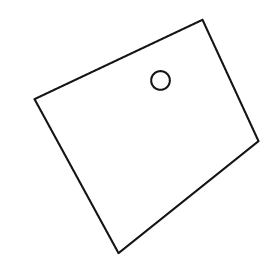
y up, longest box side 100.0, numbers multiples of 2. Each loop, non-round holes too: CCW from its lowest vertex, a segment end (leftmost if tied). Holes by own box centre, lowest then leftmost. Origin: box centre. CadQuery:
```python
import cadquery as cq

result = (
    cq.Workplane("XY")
    .moveTo(-12.0, -50.0)
    .lineTo(48.0, -2.0)
    .lineTo(24.0, 50.0)
    .lineTo(-48.0, 16.0)
    .close()
    .moveTo(6.0, 24.0)
    .circle(4.0)
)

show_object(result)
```